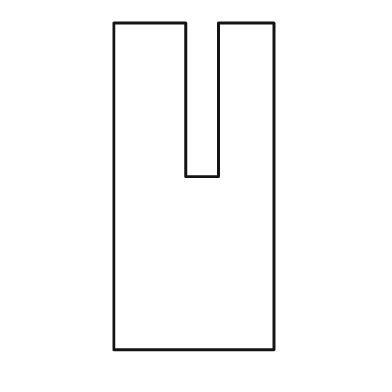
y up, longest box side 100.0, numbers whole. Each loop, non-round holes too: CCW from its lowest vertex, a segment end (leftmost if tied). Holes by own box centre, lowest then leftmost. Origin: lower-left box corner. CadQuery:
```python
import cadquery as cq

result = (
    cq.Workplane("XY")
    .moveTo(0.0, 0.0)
    .lineTo(49.0, 0.0)
    .lineTo(49.0, 100.0)
    .lineTo(32.0, 100.0)
    .lineTo(32.0, 53.0)
    .lineTo(22.0, 53.0)
    .lineTo(22.0, 100.0)
    .lineTo(0.0, 100.0)
    .close()
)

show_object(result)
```